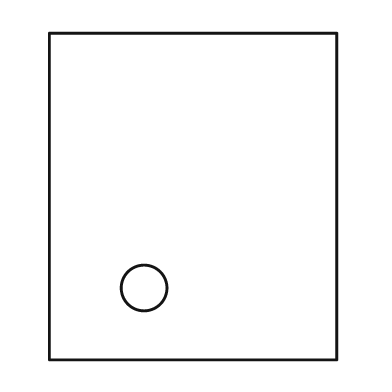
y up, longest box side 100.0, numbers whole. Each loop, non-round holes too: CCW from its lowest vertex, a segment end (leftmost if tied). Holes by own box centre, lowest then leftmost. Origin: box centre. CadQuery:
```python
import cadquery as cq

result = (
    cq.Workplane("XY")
    .moveTo(-44.0, -50.0)
    .lineTo(44.0, -50.0)
    .lineTo(44.0, 50.0)
    .lineTo(-44.0, 50.0)
    .close()
    .moveTo(-15.0, -28.0)
    .circle(7.0)
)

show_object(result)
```